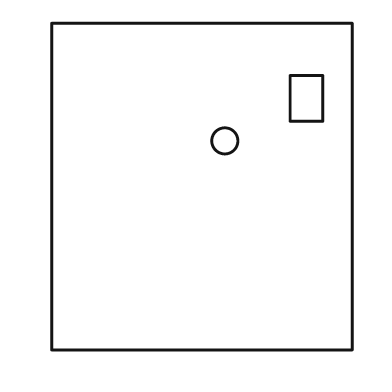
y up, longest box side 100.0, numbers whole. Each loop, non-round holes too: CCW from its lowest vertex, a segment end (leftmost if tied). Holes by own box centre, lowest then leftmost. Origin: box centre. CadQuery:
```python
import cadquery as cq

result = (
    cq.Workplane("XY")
    .moveTo(-46.0, -50.0)
    .lineTo(46.0, -50.0)
    .lineTo(46.0, 50.0)
    .lineTo(-46.0, 50.0)
    .close()
    .moveTo(7.0, 14.0)
    .circle(4.0)
    .moveTo(27.0, 20.0)
    .lineTo(37.0, 20.0)
    .lineTo(37.0, 34.0)
    .lineTo(27.0, 34.0)
    .close()
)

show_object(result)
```